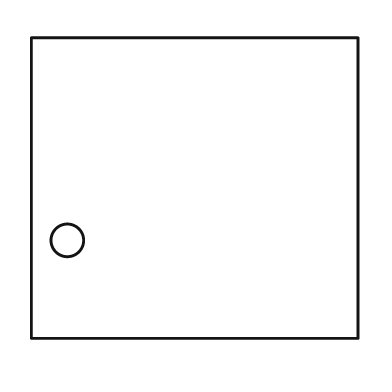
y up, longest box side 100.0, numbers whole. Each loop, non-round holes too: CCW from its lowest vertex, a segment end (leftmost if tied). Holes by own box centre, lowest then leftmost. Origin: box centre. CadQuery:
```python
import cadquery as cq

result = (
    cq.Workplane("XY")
    .moveTo(-50.0, -46.0)
    .lineTo(50.0, -46.0)
    .lineTo(50.0, 46.0)
    .lineTo(-50.0, 46.0)
    .close()
    .moveTo(-39.0, -16.0)
    .circle(5.0)
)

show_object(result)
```